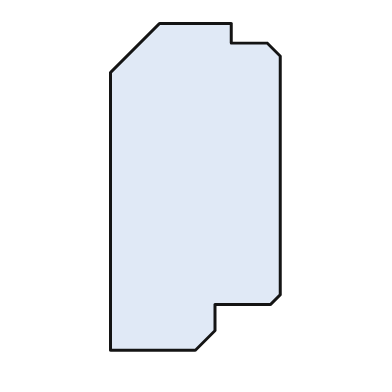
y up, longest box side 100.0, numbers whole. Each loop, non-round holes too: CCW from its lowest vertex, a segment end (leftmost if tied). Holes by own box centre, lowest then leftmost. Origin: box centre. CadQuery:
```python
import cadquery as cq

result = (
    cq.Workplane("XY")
    .moveTo(-26.0, -50.0)
    .lineTo(0.0, -50.0)
    .lineTo(6.0, -44.0)
    .lineTo(6.0, -36.0)
    .lineTo(23.0, -36.0)
    .lineTo(26.0, -33.0)
    .lineTo(26.0, 40.0)
    .lineTo(22.0, 44.0)
    .lineTo(11.0, 44.0)
    .lineTo(11.0, 50.0)
    .lineTo(-11.0, 50.0)
    .lineTo(-26.0, 35.0)
    .close()
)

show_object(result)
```